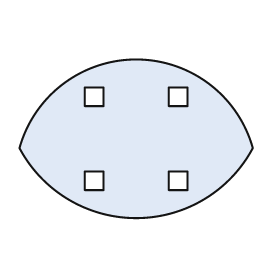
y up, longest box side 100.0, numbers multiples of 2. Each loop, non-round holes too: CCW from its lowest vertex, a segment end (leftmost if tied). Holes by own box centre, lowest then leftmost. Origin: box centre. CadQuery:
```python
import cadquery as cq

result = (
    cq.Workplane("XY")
    .moveTo(-50.0, -4.0)
    .threePointArc((0.0, -34.0), (50.0, -4.0))
    .threePointArc((0.0, 34.0), (-50.0, -4.0))
    .close()
    .moveTo(-22.0, -22.0)
    .lineTo(-14.0, -22.0)
    .lineTo(-14.0, -14.0)
    .lineTo(-22.0, -14.0)
    .close()
    .moveTo(14.0, -22.0)
    .lineTo(22.0, -22.0)
    .lineTo(22.0, -14.0)
    .lineTo(14.0, -14.0)
    .close()
    .moveTo(-22.0, 14.0)
    .lineTo(-14.0, 14.0)
    .lineTo(-14.0, 22.0)
    .lineTo(-22.0, 22.0)
    .close()
    .moveTo(14.0, 14.0)
    .lineTo(22.0, 14.0)
    .lineTo(22.0, 22.0)
    .lineTo(14.0, 22.0)
    .close()
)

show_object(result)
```